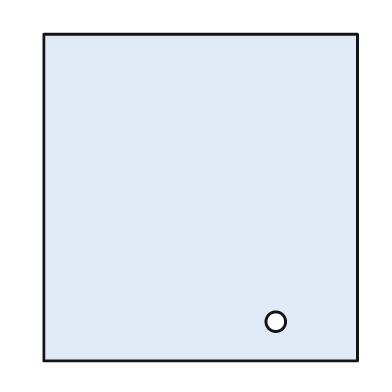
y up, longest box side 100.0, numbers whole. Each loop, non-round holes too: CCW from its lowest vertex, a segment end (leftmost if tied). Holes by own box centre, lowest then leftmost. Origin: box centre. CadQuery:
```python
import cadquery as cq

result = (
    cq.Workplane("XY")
    .moveTo(-48.0, -50.0)
    .lineTo(48.0, -50.0)
    .lineTo(48.0, 50.0)
    .lineTo(-48.0, 50.0)
    .close()
    .moveTo(23.0, -38.0)
    .circle(3.0)
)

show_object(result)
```